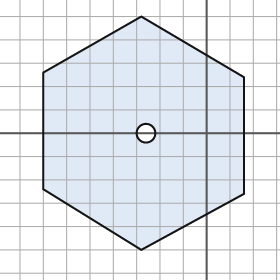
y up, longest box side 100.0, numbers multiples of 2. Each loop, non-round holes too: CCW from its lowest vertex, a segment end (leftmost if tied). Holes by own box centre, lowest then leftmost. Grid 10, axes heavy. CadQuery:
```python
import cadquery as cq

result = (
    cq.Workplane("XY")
    .moveTo(-28.0, -50.0)
    .lineTo(16.0, -26.0)
    .lineTo(16.0, 24.0)
    .lineTo(-28.0, 50.0)
    .lineTo(-70.0, 26.0)
    .lineTo(-70.0, -24.0)
    .close()
    .moveTo(-26.0, 0.0)
    .circle(4.0)
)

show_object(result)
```